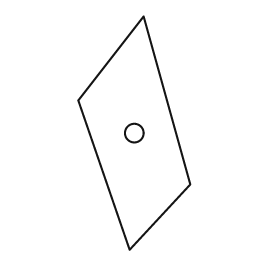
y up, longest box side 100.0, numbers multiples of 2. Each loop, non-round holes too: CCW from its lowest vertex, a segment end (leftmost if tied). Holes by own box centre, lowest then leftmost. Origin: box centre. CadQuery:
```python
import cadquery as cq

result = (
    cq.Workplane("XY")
    .moveTo(-2.0, -50.0)
    .lineTo(24.0, -22.0)
    .lineTo(4.0, 50.0)
    .lineTo(-24.0, 14.0)
    .close()
    .moveTo(0.0, 0.0)
    .circle(4.0)
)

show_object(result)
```